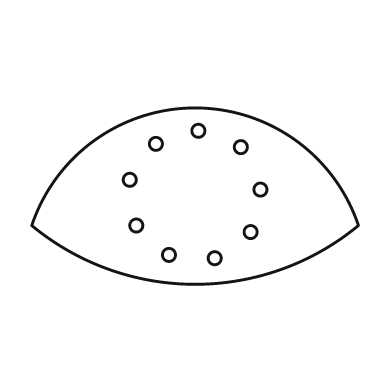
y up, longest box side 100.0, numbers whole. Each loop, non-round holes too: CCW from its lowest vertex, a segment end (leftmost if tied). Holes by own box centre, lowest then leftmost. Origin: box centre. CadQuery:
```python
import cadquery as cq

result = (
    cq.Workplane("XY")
    .moveTo(-50.0, -9.0)
    .threePointArc((0.0, -27.0), (50.0, -9.0))
    .threePointArc((0.0, 27.0), (-50.0, -9.0))
    .close()
    .moveTo(6.0, -19.0)
    .circle(2.0)
    .moveTo(-8.0, -18.0)
    .circle(2.0)
    .moveTo(17.0, -11.0)
    .circle(2.0)
    .moveTo(-18.0, -9.0)
    .circle(2.0)
    .moveTo(20.0, 2.0)
    .circle(2.0)
    .moveTo(-20.0, 5.0)
    .circle(2.0)
    .moveTo(14.0, 15.0)
    .circle(2.0)
    .moveTo(-12.0, 16.0)
    .circle(2.0)
    .moveTo(1.0, 20.0)
    .circle(2.0)
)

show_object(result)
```